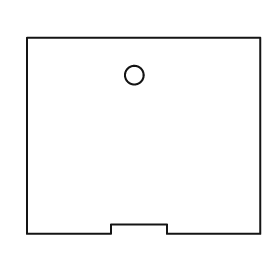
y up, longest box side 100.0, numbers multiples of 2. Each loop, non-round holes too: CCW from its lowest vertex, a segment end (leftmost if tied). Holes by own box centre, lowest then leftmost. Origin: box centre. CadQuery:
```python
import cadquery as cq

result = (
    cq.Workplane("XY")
    .moveTo(-50.0, -42.0)
    .lineTo(-14.0, -42.0)
    .lineTo(-14.0, -38.0)
    .lineTo(10.0, -38.0)
    .lineTo(10.0, -42.0)
    .lineTo(50.0, -42.0)
    .lineTo(50.0, 42.0)
    .lineTo(-50.0, 42.0)
    .close()
    .moveTo(-4.0, 26.0)
    .circle(4.0)
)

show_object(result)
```